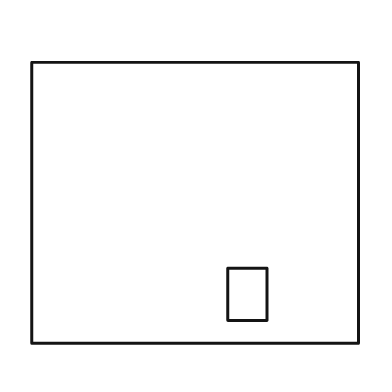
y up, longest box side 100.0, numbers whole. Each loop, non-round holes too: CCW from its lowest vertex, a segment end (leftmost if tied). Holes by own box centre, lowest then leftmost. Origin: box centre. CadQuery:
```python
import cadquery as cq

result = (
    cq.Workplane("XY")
    .moveTo(-50.0, -43.0)
    .lineTo(50.0, -43.0)
    .lineTo(50.0, 43.0)
    .lineTo(-50.0, 43.0)
    .close()
    .moveTo(10.0, -36.0)
    .lineTo(22.0, -36.0)
    .lineTo(22.0, -20.0)
    .lineTo(10.0, -20.0)
    .close()
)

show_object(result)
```